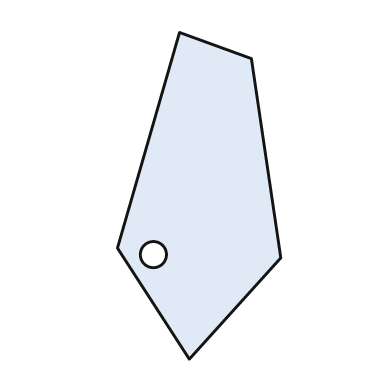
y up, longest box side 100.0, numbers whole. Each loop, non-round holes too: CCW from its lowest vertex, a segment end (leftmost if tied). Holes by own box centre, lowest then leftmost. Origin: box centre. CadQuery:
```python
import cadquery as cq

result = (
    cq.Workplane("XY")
    .moveTo(-3.0, -50.0)
    .lineTo(25.0, -19.0)
    .lineTo(16.0, 42.0)
    .lineTo(-6.0, 50.0)
    .lineTo(-25.0, -16.0)
    .close()
    .moveTo(-14.0, -18.0)
    .circle(4.0)
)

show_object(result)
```